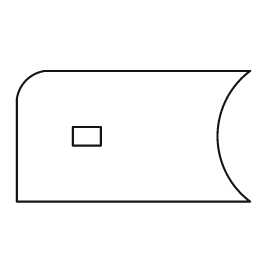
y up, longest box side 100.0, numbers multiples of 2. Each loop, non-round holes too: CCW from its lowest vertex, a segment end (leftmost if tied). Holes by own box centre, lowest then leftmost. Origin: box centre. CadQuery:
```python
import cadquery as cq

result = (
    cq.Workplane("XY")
    .moveTo(-50.0, -28.0)
    .lineTo(50.0, -28.0)
    .threePointArc((36.0, 0.0), (50.0, 28.0))
    .lineTo(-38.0, 28.0)
    .threePointArc((-46.0, 24.0), (-50.0, 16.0))
    .close()
    .moveTo(-26.0, -4.0)
    .lineTo(-14.0, -4.0)
    .lineTo(-14.0, 4.0)
    .lineTo(-26.0, 4.0)
    .close()
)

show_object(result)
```